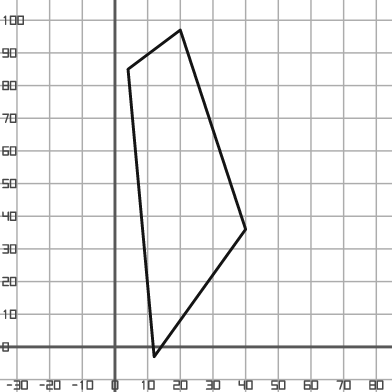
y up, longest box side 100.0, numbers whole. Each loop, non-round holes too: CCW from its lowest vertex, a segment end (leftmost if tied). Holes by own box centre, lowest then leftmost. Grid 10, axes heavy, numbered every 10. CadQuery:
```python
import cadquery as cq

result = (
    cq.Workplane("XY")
    .moveTo(12.0, -3.0)
    .lineTo(40.0, 36.0)
    .lineTo(20.0, 97.0)
    .lineTo(4.0, 85.0)
    .close()
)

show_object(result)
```